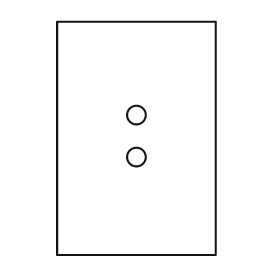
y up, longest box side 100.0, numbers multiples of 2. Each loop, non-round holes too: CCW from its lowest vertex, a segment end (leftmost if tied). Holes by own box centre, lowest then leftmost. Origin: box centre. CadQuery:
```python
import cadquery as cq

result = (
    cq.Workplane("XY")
    .moveTo(-34.0, -50.0)
    .lineTo(34.0, -50.0)
    .lineTo(34.0, 50.0)
    .lineTo(-34.0, 50.0)
    .close()
    .moveTo(0.0, -8.0)
    .circle(4.0)
    .moveTo(0.0, 10.0)
    .circle(4.0)
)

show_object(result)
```